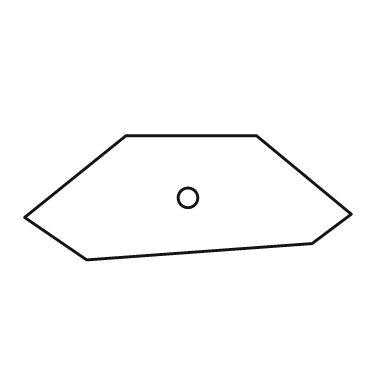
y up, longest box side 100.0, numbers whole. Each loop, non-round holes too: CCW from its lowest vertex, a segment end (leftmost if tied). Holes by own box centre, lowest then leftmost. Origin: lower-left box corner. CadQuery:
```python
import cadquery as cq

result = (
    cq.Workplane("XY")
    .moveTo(19.0, 0.0)
    .lineTo(88.0, 5.0)
    .lineTo(100.0, 14.0)
    .lineTo(71.0, 38.0)
    .lineTo(31.0, 38.0)
    .lineTo(0.0, 13.0)
    .close()
    .moveTo(50.0, 19.0)
    .circle(3.0)
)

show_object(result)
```